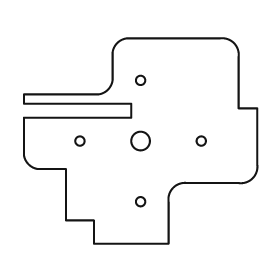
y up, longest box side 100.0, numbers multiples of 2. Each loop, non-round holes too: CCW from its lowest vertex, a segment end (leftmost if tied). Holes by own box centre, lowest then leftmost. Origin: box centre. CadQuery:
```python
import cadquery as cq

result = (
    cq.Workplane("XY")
    .moveTo(-20.0, -44.0)
    .lineTo(12.0, -44.0)
    .lineTo(12.0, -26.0)
    .threePointArc((14.0, -20.0), (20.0, -18.0))
    .lineTo(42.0, -18.0)
    .threePointArc((48.0, -16.0), (50.0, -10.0))
    .lineTo(50.0, 14.0)
    .lineTo(42.0, 14.0)
    .lineTo(42.0, 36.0)
    .threePointArc((40.0, 42.0), (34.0, 44.0))
    .lineTo(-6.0, 44.0)
    .threePointArc((-10.0, 42.0), (-12.0, 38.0))
    .lineTo(-12.0, 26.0)
    .threePointArc((-14.0, 22.0), (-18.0, 20.0))
    .lineTo(-50.0, 20.0)
    .lineTo(-50.0, 16.0)
    .lineTo(-4.0, 16.0)
    .lineTo(-4.0, 10.0)
    .lineTo(-50.0, 10.0)
    .lineTo(-50.0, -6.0)
    .threePointArc((-48.0, -10.0), (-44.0, -12.0))
    .lineTo(-32.0, -12.0)
    .lineTo(-32.0, -34.0)
    .lineTo(-20.0, -34.0)
    .close()
    .moveTo(0.0, -26.0)
    .circle(2.0)
    .moveTo(-26.0, 0.0)
    .circle(2.0)
    .moveTo(0.0, 0.0)
    .circle(4.0)
    .moveTo(26.0, 0.0)
    .circle(2.0)
    .moveTo(0.0, 26.0)
    .circle(2.0)
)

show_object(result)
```